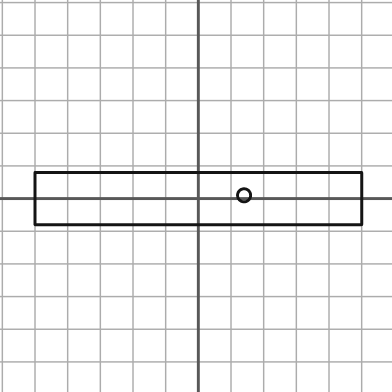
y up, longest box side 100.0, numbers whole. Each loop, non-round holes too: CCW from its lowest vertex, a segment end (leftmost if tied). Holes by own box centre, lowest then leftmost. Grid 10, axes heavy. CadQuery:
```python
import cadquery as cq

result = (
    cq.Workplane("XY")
    .moveTo(-50.0, -8.0)
    .lineTo(50.0, -8.0)
    .lineTo(50.0, 8.0)
    .lineTo(-50.0, 8.0)
    .close()
    .moveTo(14.0, 1.0)
    .circle(2.0)
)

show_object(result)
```